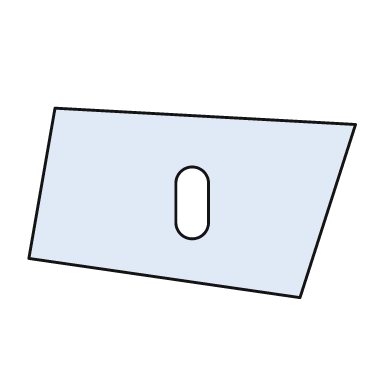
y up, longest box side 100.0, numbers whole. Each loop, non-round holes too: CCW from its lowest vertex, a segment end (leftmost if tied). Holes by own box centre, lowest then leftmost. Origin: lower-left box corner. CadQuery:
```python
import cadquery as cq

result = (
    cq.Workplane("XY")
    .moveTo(83.0, 0.0)
    .lineTo(100.0, 53.0)
    .lineTo(8.0, 58.0)
    .lineTo(0.0, 12.0)
    .close()
    .moveTo(45.0, 23.0)
    .threePointArc((50.0, 18.0), (55.0, 23.0))
    .lineTo(55.0, 35.0)
    .threePointArc((50.0, 40.0), (45.0, 35.0))
    .close()
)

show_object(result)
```